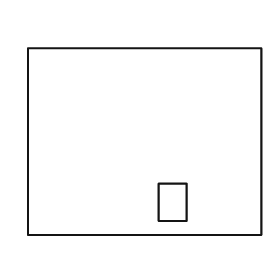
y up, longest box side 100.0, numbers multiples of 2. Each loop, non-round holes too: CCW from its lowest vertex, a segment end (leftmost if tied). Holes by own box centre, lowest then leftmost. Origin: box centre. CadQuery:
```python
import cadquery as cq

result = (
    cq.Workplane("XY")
    .moveTo(-50.0, -40.0)
    .lineTo(50.0, -40.0)
    .lineTo(50.0, 40.0)
    .lineTo(-50.0, 40.0)
    .close()
    .moveTo(6.0, -34.0)
    .lineTo(18.0, -34.0)
    .lineTo(18.0, -18.0)
    .lineTo(6.0, -18.0)
    .close()
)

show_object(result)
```